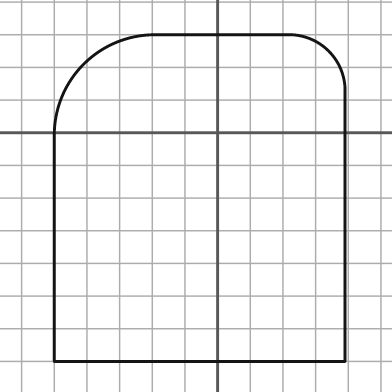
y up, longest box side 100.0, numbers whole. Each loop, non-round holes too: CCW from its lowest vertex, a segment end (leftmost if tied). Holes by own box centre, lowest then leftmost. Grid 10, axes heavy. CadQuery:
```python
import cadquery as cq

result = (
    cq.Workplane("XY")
    .moveTo(-50.0, -70.0)
    .lineTo(39.0, -70.0)
    .lineTo(39.0, 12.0)
    .threePointArc((34.0, 25.0), (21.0, 30.0))
    .lineTo(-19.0, 30.0)
    .threePointArc((-41.0, 21.0), (-50.0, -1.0))
    .close()
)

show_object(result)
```